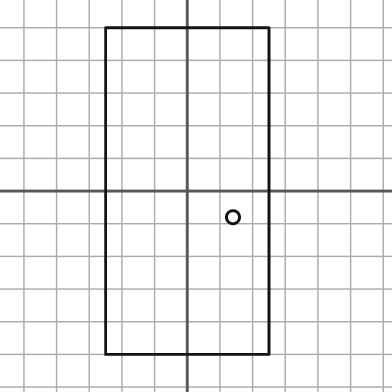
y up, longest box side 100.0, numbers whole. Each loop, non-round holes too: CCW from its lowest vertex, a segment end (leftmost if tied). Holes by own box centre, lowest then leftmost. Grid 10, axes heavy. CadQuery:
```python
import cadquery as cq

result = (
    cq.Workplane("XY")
    .moveTo(-25.0, -50.0)
    .lineTo(25.0, -50.0)
    .lineTo(25.0, 50.0)
    .lineTo(-25.0, 50.0)
    .close()
    .moveTo(14.0, -8.0)
    .circle(2.0)
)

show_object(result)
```